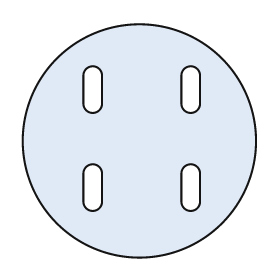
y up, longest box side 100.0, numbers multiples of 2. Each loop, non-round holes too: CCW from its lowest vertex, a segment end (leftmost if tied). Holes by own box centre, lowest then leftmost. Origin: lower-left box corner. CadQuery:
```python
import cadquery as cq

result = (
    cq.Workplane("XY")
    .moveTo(50.0, 50.0)
    .circle(50.0)
    .moveTo(26.0, 24.0)
    .threePointArc((30.0, 20.0), (34.0, 24.0))
    .lineTo(34.0, 36.0)
    .threePointArc((30.0, 40.0), (26.0, 36.0))
    .close()
    .moveTo(68.0, 24.0)
    .threePointArc((72.0, 20.0), (76.0, 24.0))
    .lineTo(76.0, 36.0)
    .threePointArc((72.0, 40.0), (68.0, 36.0))
    .close()
    .moveTo(26.0, 66.0)
    .threePointArc((30.0, 62.0), (34.0, 66.0))
    .lineTo(34.0, 78.0)
    .threePointArc((30.0, 82.0), (26.0, 78.0))
    .close()
    .moveTo(68.0, 66.0)
    .threePointArc((72.0, 62.0), (76.0, 66.0))
    .lineTo(76.0, 78.0)
    .threePointArc((72.0, 82.0), (68.0, 78.0))
    .close()
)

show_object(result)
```